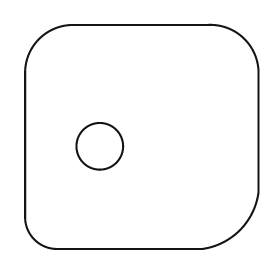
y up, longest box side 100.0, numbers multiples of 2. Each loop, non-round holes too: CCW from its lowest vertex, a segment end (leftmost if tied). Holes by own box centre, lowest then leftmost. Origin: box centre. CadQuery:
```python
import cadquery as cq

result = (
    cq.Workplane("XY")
    .moveTo(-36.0, -48.0)
    .lineTo(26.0, -48.0)
    .threePointArc((42.0, -40.0), (50.0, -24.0))
    .lineTo(50.0, 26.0)
    .threePointArc((44.0, 42.0), (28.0, 48.0))
    .lineTo(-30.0, 48.0)
    .threePointArc((-44.0, 42.0), (-50.0, 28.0))
    .lineTo(-50.0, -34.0)
    .threePointArc((-46.0, -44.0), (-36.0, -48.0))
    .close()
    .moveTo(-18.0, -4.0)
    .circle(10.0)
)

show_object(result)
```